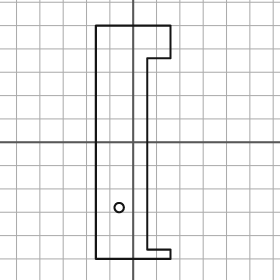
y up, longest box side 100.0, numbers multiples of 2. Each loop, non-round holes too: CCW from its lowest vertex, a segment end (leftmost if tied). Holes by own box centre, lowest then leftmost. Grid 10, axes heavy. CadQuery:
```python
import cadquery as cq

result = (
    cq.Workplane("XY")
    .moveTo(-16.0, -50.0)
    .lineTo(16.0, -50.0)
    .lineTo(16.0, -46.0)
    .lineTo(6.0, -46.0)
    .lineTo(6.0, 36.0)
    .lineTo(16.0, 36.0)
    .lineTo(16.0, 50.0)
    .lineTo(-16.0, 50.0)
    .close()
    .moveTo(-6.0, -28.0)
    .circle(2.0)
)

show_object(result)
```